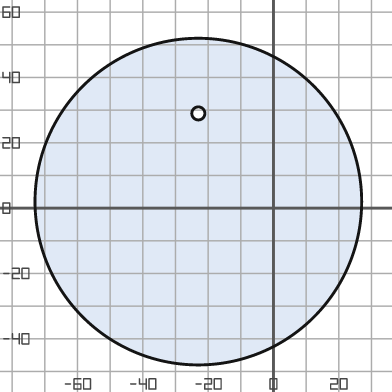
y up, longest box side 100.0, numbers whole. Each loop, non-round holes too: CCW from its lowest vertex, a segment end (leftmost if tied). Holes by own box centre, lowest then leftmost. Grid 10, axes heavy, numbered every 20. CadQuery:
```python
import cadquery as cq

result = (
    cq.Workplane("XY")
    .moveTo(-23.0, 2.0)
    .circle(50.0)
    .moveTo(-23.0, 29.0)
    .circle(2.0)
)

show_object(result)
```